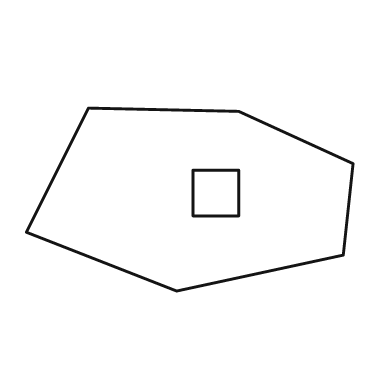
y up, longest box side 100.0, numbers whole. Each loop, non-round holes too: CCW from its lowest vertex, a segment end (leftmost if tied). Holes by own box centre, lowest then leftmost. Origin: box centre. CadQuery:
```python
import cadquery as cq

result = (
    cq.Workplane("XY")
    .moveTo(-4.0, -28.0)
    .lineTo(47.0, -17.0)
    .lineTo(50.0, 11.0)
    .lineTo(15.0, 27.0)
    .lineTo(-31.0, 28.0)
    .lineTo(-50.0, -10.0)
    .close()
    .moveTo(1.0, -5.0)
    .lineTo(15.0, -5.0)
    .lineTo(15.0, 9.0)
    .lineTo(1.0, 9.0)
    .close()
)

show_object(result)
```